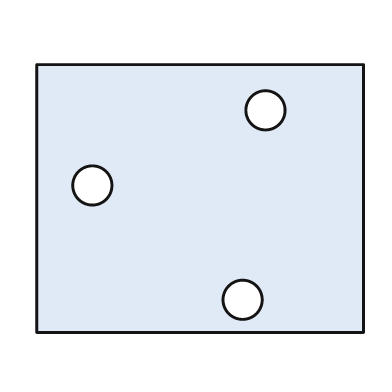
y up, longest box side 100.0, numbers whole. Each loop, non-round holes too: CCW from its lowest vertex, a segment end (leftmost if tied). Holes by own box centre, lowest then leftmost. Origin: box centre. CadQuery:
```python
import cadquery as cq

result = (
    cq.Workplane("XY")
    .moveTo(-50.0, -41.0)
    .lineTo(50.0, -41.0)
    .lineTo(50.0, 41.0)
    .lineTo(-50.0, 41.0)
    .close()
    .moveTo(13.0, -31.0)
    .circle(6.0)
    .moveTo(-33.0, 4.0)
    .circle(6.0)
    .moveTo(20.0, 27.0)
    .circle(6.0)
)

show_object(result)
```